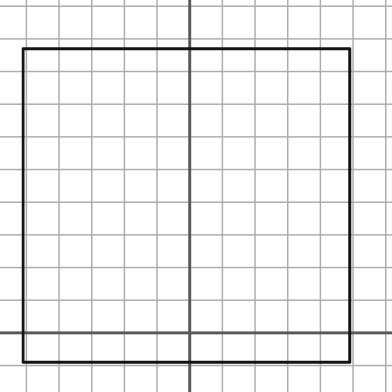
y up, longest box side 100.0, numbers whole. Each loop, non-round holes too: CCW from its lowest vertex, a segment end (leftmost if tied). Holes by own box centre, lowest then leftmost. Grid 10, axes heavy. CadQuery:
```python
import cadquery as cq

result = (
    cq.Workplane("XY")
    .moveTo(-51.0, -9.0)
    .lineTo(49.0, -9.0)
    .lineTo(49.0, 87.0)
    .lineTo(-51.0, 87.0)
    .close()
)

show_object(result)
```